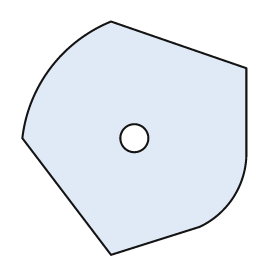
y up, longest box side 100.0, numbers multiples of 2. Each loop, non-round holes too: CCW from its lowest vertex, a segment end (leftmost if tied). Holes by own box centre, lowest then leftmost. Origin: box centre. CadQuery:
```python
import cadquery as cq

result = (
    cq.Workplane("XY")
    .moveTo(-10.0, -50.0)
    .lineTo(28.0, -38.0)
    .threePointArc((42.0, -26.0), (48.0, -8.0))
    .lineTo(48.0, 30.0)
    .lineTo(-10.0, 50.0)
    .threePointArc((-36.0, 30.0), (-48.0, 0.0))
    .close()
    .moveTo(0.0, 0.0)
    .circle(6.0)
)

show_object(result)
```